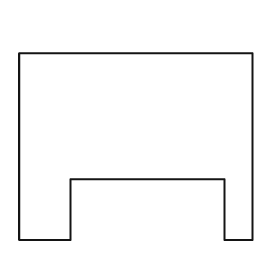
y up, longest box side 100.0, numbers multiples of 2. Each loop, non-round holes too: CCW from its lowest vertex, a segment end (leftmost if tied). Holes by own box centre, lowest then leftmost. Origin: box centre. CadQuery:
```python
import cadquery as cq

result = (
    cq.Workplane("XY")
    .moveTo(-50.0, -40.0)
    .lineTo(-28.0, -40.0)
    .lineTo(-28.0, -14.0)
    .lineTo(38.0, -14.0)
    .lineTo(38.0, -40.0)
    .lineTo(50.0, -40.0)
    .lineTo(50.0, 40.0)
    .lineTo(-50.0, 40.0)
    .close()
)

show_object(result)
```